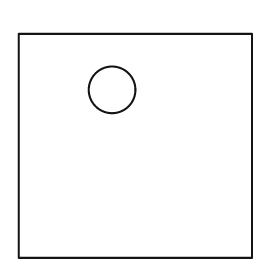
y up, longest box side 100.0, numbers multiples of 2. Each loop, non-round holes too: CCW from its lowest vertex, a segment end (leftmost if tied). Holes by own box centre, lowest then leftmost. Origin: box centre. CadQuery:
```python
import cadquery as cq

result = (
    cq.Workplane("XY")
    .moveTo(-50.0, -48.0)
    .lineTo(50.0, -48.0)
    .lineTo(50.0, 48.0)
    .lineTo(-50.0, 48.0)
    .close()
    .moveTo(-10.0, 24.0)
    .circle(10.0)
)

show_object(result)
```